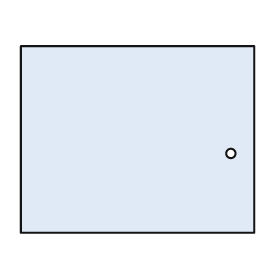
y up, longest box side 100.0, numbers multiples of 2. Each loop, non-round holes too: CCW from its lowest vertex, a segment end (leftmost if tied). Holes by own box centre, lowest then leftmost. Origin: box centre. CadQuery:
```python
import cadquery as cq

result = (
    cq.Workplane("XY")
    .moveTo(-50.0, -40.0)
    .lineTo(50.0, -40.0)
    .lineTo(50.0, 40.0)
    .lineTo(-50.0, 40.0)
    .close()
    .moveTo(40.0, -6.0)
    .circle(2.0)
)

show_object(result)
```